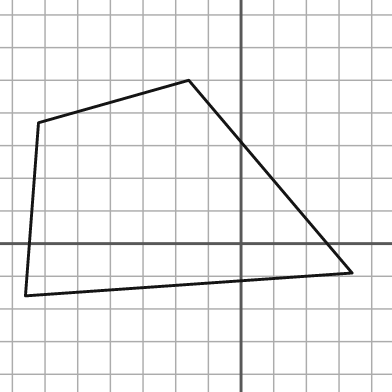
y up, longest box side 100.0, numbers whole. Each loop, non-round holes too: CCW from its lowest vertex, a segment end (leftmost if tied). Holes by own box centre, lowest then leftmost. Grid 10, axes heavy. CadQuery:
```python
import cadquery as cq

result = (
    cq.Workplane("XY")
    .moveTo(-66.0, -16.0)
    .lineTo(34.0, -9.0)
    .lineTo(-16.0, 50.0)
    .lineTo(-62.0, 37.0)
    .close()
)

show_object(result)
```